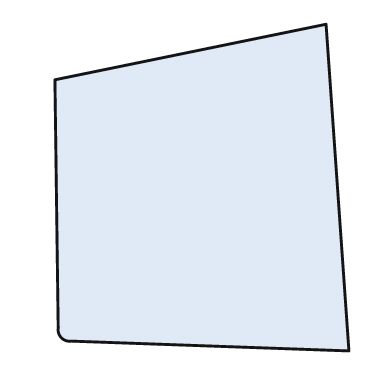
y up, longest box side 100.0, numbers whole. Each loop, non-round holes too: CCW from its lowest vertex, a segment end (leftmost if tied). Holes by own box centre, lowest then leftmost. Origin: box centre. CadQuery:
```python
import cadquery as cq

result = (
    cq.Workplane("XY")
    .moveTo(45.0, -50.0)
    .lineTo(38.0, 50.0)
    .lineTo(-45.0, 33.0)
    .lineTo(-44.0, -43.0)
    .threePointArc((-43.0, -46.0), (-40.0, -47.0))
    .close()
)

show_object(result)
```